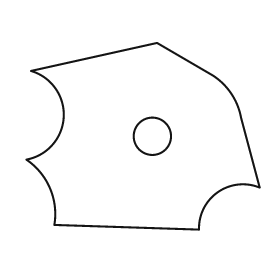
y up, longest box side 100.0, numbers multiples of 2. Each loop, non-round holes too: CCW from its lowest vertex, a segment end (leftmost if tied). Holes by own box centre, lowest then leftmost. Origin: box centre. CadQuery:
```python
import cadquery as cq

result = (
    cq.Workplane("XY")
    .moveTo(24.0, -40.0)
    .threePointArc((32.0, -24.0), (50.0, -22.0))
    .lineTo(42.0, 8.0)
    .threePointArc((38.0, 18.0), (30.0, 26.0))
    .lineTo(6.0, 40.0)
    .lineTo(-48.0, 28.0)
    .threePointArc((-34.0, 8.0), (-50.0, -10.0))
    .threePointArc((-40.0, -22.0), (-38.0, -38.0))
    .close()
    .moveTo(4.0, 0.0)
    .circle(8.0)
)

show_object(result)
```